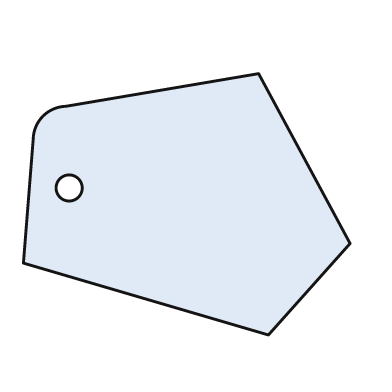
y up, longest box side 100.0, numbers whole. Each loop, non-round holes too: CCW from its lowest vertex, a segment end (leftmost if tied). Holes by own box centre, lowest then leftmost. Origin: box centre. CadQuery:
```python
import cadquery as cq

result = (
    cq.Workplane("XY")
    .moveTo(25.0, -40.0)
    .lineTo(50.0, -12.0)
    .lineTo(22.0, 40.0)
    .lineTo(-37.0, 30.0)
    .threePointArc((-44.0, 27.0), (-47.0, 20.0))
    .lineTo(-50.0, -18.0)
    .close()
    .moveTo(-36.0, 5.0)
    .circle(4.0)
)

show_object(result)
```